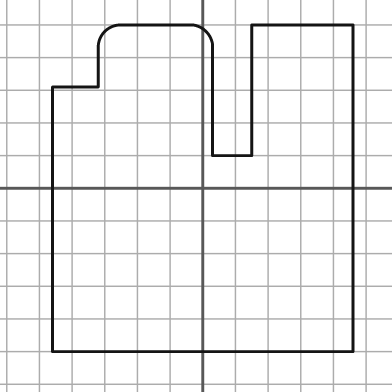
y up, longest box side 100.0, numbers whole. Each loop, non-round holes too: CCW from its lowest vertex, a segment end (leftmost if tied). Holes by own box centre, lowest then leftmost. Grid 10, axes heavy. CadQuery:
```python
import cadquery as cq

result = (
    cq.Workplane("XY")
    .moveTo(-46.0, -50.0)
    .lineTo(46.0, -50.0)
    .lineTo(46.0, 50.0)
    .lineTo(15.0, 50.0)
    .lineTo(15.0, 10.0)
    .lineTo(3.0, 10.0)
    .lineTo(3.0, 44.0)
    .threePointArc((1.0, 48.0), (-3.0, 50.0))
    .lineTo(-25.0, 50.0)
    .threePointArc((-30.0, 48.0), (-32.0, 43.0))
    .lineTo(-32.0, 31.0)
    .lineTo(-46.0, 31.0)
    .close()
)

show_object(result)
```